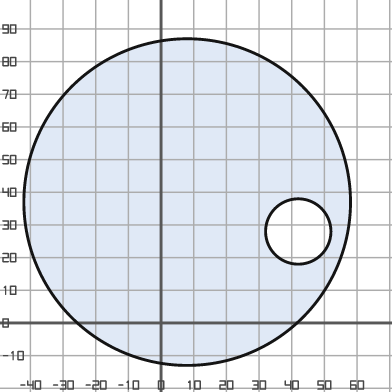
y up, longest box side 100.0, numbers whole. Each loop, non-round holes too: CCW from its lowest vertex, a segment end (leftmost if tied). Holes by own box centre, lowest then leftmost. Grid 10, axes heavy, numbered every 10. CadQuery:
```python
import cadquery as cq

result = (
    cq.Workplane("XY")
    .moveTo(8.0, 37.0)
    .circle(50.0)
    .moveTo(42.0, 28.0)
    .circle(10.0)
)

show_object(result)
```